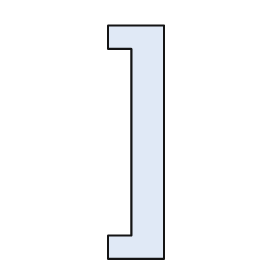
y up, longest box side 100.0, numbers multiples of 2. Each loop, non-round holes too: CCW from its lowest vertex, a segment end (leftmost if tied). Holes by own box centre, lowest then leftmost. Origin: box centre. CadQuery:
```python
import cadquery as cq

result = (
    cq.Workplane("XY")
    .moveTo(-12.0, -50.0)
    .lineTo(12.0, -50.0)
    .lineTo(12.0, 50.0)
    .lineTo(-12.0, 50.0)
    .lineTo(-12.0, 40.0)
    .lineTo(-2.0, 40.0)
    .lineTo(-2.0, -40.0)
    .lineTo(-12.0, -40.0)
    .close()
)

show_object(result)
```